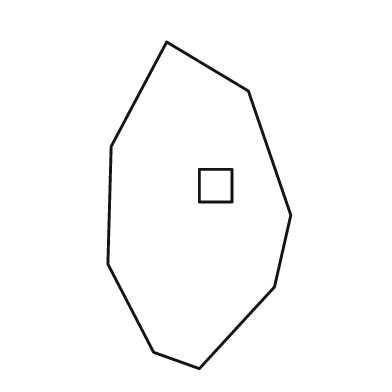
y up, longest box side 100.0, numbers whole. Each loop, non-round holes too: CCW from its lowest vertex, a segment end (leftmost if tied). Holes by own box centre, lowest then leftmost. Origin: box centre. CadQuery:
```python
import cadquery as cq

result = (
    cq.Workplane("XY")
    .moveTo(0.0, -50.0)
    .lineTo(23.0, -25.0)
    .lineTo(28.0, -3.0)
    .lineTo(15.0, 35.0)
    .lineTo(-10.0, 50.0)
    .lineTo(-27.0, 18.0)
    .lineTo(-28.0, -18.0)
    .lineTo(-14.0, -45.0)
    .close()
    .moveTo(0.0, 1.0)
    .lineTo(10.0, 1.0)
    .lineTo(10.0, 11.0)
    .lineTo(0.0, 11.0)
    .close()
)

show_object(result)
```